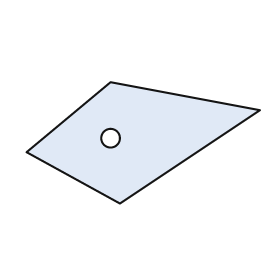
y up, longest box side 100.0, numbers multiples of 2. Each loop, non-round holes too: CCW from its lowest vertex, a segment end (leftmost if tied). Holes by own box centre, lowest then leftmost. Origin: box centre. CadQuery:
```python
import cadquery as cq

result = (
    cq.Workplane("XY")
    .moveTo(-10.0, -26.0)
    .lineTo(50.0, 14.0)
    .lineTo(-14.0, 26.0)
    .lineTo(-50.0, -4.0)
    .close()
    .moveTo(-14.0, 2.0)
    .circle(4.0)
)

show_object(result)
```